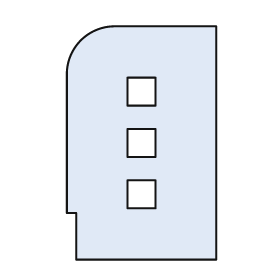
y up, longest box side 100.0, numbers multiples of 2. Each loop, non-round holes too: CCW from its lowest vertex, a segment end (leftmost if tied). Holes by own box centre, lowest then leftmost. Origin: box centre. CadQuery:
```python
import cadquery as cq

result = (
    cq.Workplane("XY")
    .moveTo(-28.0, -50.0)
    .lineTo(32.0, -50.0)
    .lineTo(32.0, 50.0)
    .lineTo(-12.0, 50.0)
    .threePointArc((-26.0, 44.0), (-32.0, 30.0))
    .lineTo(-32.0, -30.0)
    .lineTo(-28.0, -30.0)
    .close()
    .moveTo(-6.0, -28.0)
    .lineTo(6.0, -28.0)
    .lineTo(6.0, -16.0)
    .lineTo(-6.0, -16.0)
    .close()
    .moveTo(-6.0, -6.0)
    .lineTo(6.0, -6.0)
    .lineTo(6.0, 6.0)
    .lineTo(-6.0, 6.0)
    .close()
    .moveTo(-6.0, 16.0)
    .lineTo(6.0, 16.0)
    .lineTo(6.0, 28.0)
    .lineTo(-6.0, 28.0)
    .close()
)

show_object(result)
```